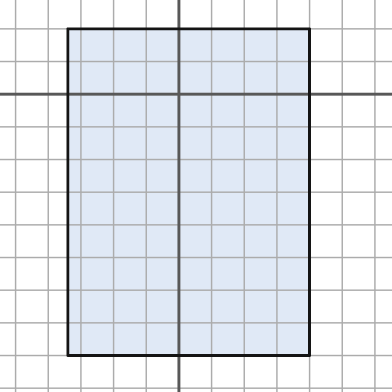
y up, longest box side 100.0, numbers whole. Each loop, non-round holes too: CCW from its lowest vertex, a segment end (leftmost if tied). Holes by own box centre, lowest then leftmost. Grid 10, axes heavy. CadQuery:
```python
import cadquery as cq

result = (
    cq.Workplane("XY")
    .moveTo(-34.0, -80.0)
    .lineTo(40.0, -80.0)
    .lineTo(40.0, 20.0)
    .lineTo(-34.0, 20.0)
    .close()
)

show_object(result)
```